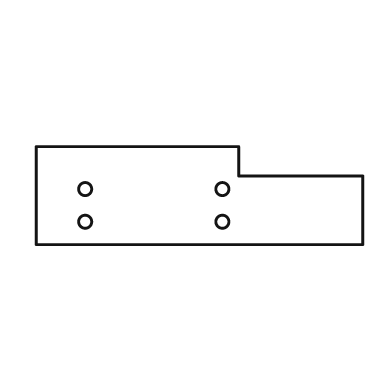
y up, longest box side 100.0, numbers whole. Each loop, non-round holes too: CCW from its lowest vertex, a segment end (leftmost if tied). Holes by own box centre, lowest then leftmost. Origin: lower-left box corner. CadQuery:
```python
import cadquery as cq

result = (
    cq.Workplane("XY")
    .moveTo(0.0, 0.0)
    .lineTo(100.0, 0.0)
    .lineTo(100.0, 21.0)
    .lineTo(62.0, 21.0)
    .lineTo(62.0, 30.0)
    .lineTo(0.0, 30.0)
    .close()
    .moveTo(15.0, 7.0)
    .circle(2.0)
    .moveTo(57.0, 7.0)
    .circle(2.0)
    .moveTo(15.0, 17.0)
    .circle(2.0)
    .moveTo(57.0, 17.0)
    .circle(2.0)
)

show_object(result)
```